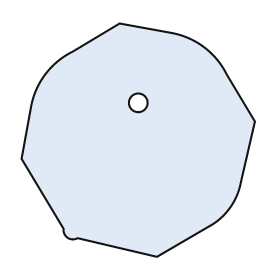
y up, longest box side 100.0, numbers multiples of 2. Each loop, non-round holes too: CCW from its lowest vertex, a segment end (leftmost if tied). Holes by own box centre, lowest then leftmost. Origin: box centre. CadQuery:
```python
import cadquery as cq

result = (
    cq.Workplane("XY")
    .moveTo(8.0, -50.0)
    .lineTo(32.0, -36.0)
    .threePointArc((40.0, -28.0), (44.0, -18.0))
    .lineTo(50.0, 8.0)
    .lineTo(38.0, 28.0)
    .threePointArc((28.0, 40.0), (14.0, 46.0))
    .lineTo(-8.0, 50.0)
    .lineTo(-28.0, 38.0)
    .threePointArc((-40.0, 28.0), (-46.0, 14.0))
    .lineTo(-50.0, -8.0)
    .lineTo(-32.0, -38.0)
    .threePointArc((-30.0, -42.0), (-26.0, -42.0))
    .close()
    .moveTo(0.0, 16.0)
    .circle(4.0)
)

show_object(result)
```